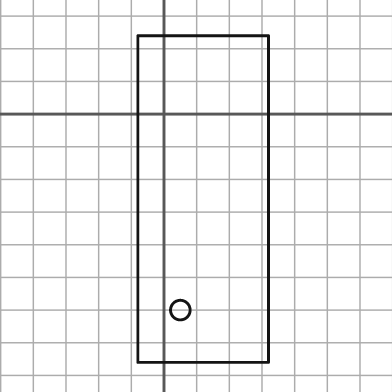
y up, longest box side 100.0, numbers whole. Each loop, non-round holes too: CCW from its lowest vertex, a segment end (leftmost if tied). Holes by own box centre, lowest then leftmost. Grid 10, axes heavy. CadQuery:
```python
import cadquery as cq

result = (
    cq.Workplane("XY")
    .moveTo(-8.0, -76.0)
    .lineTo(32.0, -76.0)
    .lineTo(32.0, 24.0)
    .lineTo(-8.0, 24.0)
    .close()
    .moveTo(5.0, -60.0)
    .circle(3.0)
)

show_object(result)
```